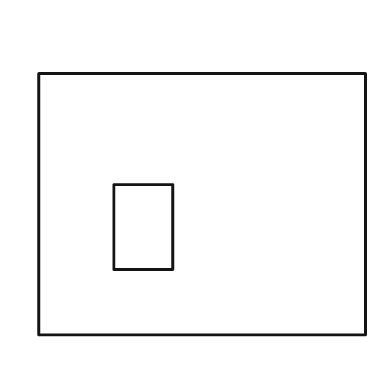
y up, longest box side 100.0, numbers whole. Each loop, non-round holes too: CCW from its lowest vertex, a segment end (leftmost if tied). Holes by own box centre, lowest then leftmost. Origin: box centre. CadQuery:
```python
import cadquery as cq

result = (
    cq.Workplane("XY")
    .moveTo(-50.0, -40.0)
    .lineTo(50.0, -40.0)
    .lineTo(50.0, 40.0)
    .lineTo(-50.0, 40.0)
    .close()
    .moveTo(-27.0, -20.0)
    .lineTo(-9.0, -20.0)
    .lineTo(-9.0, 6.0)
    .lineTo(-27.0, 6.0)
    .close()
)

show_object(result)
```